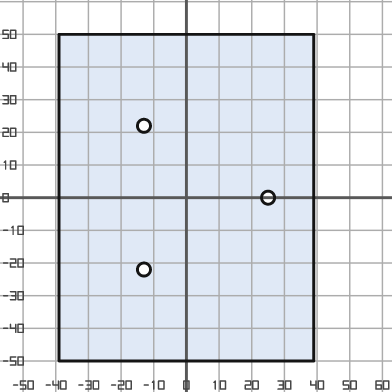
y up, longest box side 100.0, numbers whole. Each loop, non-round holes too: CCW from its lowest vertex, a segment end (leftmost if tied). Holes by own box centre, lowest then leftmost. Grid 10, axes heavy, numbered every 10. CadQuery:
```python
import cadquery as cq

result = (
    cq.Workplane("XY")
    .moveTo(-39.0, -50.0)
    .lineTo(39.0, -50.0)
    .lineTo(39.0, 50.0)
    .lineTo(-39.0, 50.0)
    .close()
    .moveTo(-13.0, -22.0)
    .circle(2.0)
    .moveTo(25.0, 0.0)
    .circle(2.0)
    .moveTo(-13.0, 22.0)
    .circle(2.0)
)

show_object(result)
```